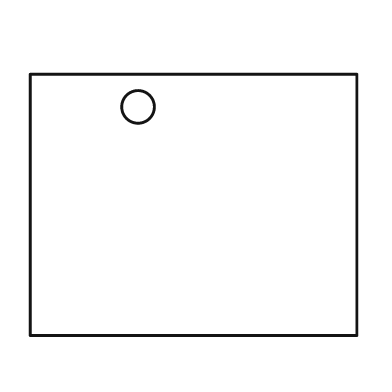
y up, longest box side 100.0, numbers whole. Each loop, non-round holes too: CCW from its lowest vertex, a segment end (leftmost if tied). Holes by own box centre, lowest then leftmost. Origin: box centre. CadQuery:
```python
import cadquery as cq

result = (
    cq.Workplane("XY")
    .moveTo(-50.0, -40.0)
    .lineTo(50.0, -40.0)
    .lineTo(50.0, 40.0)
    .lineTo(-50.0, 40.0)
    .close()
    .moveTo(-17.0, 30.0)
    .circle(5.0)
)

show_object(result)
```